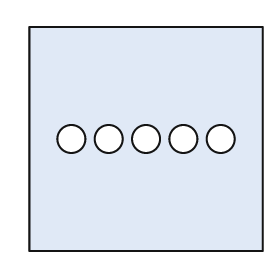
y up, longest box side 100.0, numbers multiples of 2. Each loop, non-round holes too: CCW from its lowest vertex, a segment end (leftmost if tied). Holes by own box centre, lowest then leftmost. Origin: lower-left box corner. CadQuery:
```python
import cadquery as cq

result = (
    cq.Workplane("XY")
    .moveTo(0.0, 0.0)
    .lineTo(100.0, 0.0)
    .lineTo(100.0, 96.0)
    .lineTo(0.0, 96.0)
    .close()
    .moveTo(18.0, 48.0)
    .circle(6.0)
    .moveTo(34.0, 48.0)
    .circle(6.0)
    .moveTo(50.0, 48.0)
    .circle(6.0)
    .moveTo(66.0, 48.0)
    .circle(6.0)
    .moveTo(82.0, 48.0)
    .circle(6.0)
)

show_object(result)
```